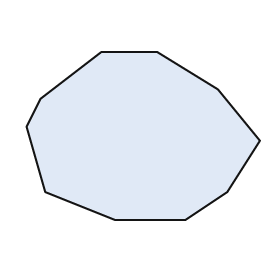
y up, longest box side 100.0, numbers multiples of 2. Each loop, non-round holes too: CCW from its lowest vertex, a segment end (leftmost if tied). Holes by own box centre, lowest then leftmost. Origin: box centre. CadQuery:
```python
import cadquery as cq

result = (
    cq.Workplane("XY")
    .moveTo(-12.0, -36.0)
    .lineTo(18.0, -36.0)
    .lineTo(36.0, -24.0)
    .lineTo(50.0, -2.0)
    .lineTo(32.0, 20.0)
    .lineTo(6.0, 36.0)
    .lineTo(-18.0, 36.0)
    .lineTo(-44.0, 16.0)
    .lineTo(-50.0, 4.0)
    .lineTo(-42.0, -24.0)
    .close()
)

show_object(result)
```